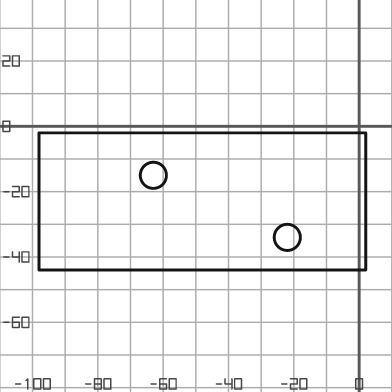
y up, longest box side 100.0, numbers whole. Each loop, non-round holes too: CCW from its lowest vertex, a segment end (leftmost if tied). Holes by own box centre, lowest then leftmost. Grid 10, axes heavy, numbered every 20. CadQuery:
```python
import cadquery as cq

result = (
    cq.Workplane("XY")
    .moveTo(-98.0, -44.0)
    .lineTo(2.0, -44.0)
    .lineTo(2.0, -2.0)
    .lineTo(-98.0, -2.0)
    .close()
    .moveTo(-22.0, -34.0)
    .circle(4.0)
    .moveTo(-63.0, -15.0)
    .circle(4.0)
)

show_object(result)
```